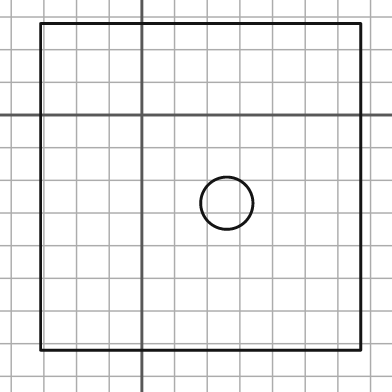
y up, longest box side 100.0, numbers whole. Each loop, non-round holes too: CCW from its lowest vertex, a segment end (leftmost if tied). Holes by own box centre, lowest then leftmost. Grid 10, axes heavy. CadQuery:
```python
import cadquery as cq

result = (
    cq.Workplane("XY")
    .moveTo(-31.0, -72.0)
    .lineTo(67.0, -72.0)
    .lineTo(67.0, 28.0)
    .lineTo(-31.0, 28.0)
    .close()
    .moveTo(26.0, -27.0)
    .circle(8.0)
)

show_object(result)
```